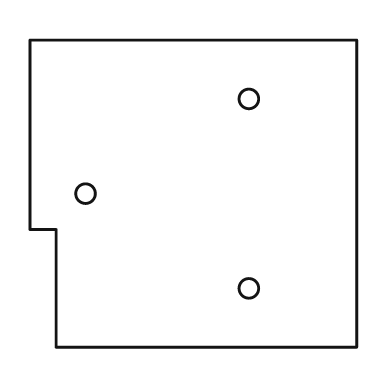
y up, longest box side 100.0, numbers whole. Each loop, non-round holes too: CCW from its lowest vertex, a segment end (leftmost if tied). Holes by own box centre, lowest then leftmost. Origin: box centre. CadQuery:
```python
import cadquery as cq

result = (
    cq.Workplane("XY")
    .moveTo(-42.0, -47.0)
    .lineTo(50.0, -47.0)
    .lineTo(50.0, 47.0)
    .lineTo(-50.0, 47.0)
    .lineTo(-50.0, -11.0)
    .lineTo(-42.0, -11.0)
    .close()
    .moveTo(17.0, -29.0)
    .circle(3.0)
    .moveTo(-33.0, 0.0)
    .circle(3.0)
    .moveTo(17.0, 29.0)
    .circle(3.0)
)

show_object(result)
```